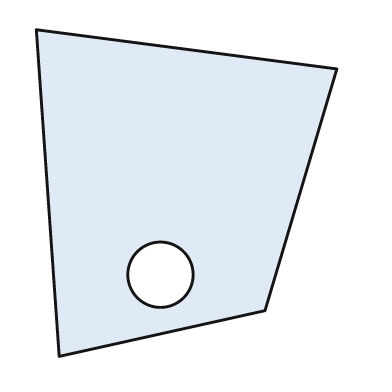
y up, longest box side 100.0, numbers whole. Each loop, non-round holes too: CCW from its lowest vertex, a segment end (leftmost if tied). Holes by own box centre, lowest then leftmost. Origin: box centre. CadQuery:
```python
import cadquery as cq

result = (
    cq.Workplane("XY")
    .moveTo(-39.0, -50.0)
    .lineTo(24.0, -36.0)
    .lineTo(46.0, 38.0)
    .lineTo(-46.0, 50.0)
    .close()
    .moveTo(-8.0, -25.0)
    .circle(10.0)
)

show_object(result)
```